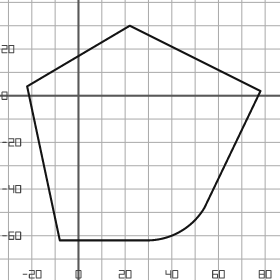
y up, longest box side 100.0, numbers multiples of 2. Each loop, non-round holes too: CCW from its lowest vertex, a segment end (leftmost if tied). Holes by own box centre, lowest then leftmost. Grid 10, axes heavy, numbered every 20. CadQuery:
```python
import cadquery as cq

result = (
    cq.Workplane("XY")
    .moveTo(-8.0, -62.0)
    .lineTo(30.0, -62.0)
    .threePointArc((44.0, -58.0), (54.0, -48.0))
    .lineTo(78.0, 2.0)
    .lineTo(22.0, 30.0)
    .lineTo(-22.0, 4.0)
    .close()
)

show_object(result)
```